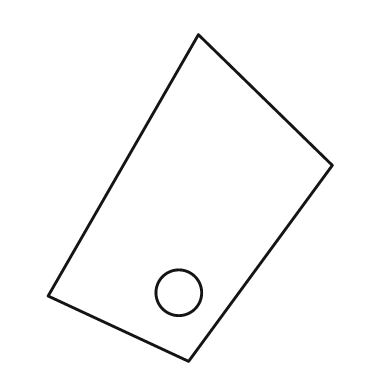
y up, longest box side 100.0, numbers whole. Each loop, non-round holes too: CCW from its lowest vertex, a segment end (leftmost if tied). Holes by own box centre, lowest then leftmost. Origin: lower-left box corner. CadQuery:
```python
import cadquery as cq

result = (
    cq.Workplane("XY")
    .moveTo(43.0, 0.0)
    .lineTo(87.0, 60.0)
    .lineTo(46.0, 100.0)
    .lineTo(0.0, 20.0)
    .close()
    .moveTo(40.0, 21.0)
    .circle(7.0)
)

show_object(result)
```